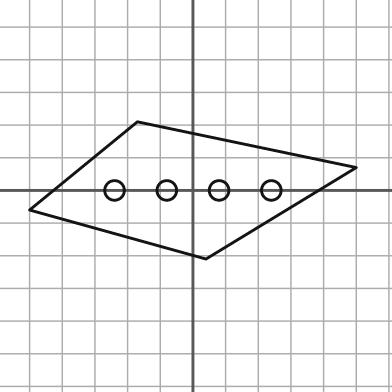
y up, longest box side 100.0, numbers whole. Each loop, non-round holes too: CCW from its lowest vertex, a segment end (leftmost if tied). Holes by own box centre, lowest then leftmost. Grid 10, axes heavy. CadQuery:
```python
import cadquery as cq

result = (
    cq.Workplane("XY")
    .moveTo(4.0, -21.0)
    .lineTo(50.0, 7.0)
    .lineTo(-17.0, 21.0)
    .lineTo(-50.0, -6.0)
    .close()
    .moveTo(-24.0, 0.0)
    .circle(3.0)
    .moveTo(-8.0, 0.0)
    .circle(3.0)
    .moveTo(8.0, 0.0)
    .circle(3.0)
    .moveTo(24.0, 0.0)
    .circle(3.0)
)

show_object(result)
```